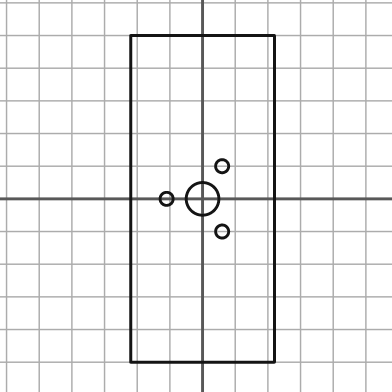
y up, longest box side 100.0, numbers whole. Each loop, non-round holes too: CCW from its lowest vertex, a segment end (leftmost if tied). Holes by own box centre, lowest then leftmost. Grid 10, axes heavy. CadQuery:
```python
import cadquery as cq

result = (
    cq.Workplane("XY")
    .moveTo(-22.0, -50.0)
    .lineTo(22.0, -50.0)
    .lineTo(22.0, 50.0)
    .lineTo(-22.0, 50.0)
    .close()
    .moveTo(6.0, -10.0)
    .circle(2.0)
    .moveTo(-11.0, 0.0)
    .circle(2.0)
    .moveTo(0.0, 0.0)
    .circle(5.0)
    .moveTo(6.0, 10.0)
    .circle(2.0)
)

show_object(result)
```